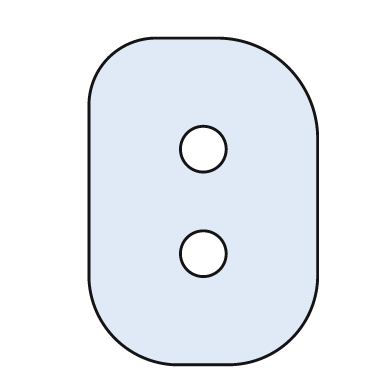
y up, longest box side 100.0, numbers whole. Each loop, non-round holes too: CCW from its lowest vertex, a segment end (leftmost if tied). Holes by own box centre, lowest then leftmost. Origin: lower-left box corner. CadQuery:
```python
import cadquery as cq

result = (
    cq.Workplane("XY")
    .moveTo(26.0, 0.0)
    .lineTo(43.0, 0.0)
    .threePointArc((62.0, 8.0), (70.0, 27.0))
    .lineTo(70.0, 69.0)
    .threePointArc((61.0, 91.0), (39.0, 100.0))
    .lineTo(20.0, 100.0)
    .threePointArc((6.0, 94.0), (0.0, 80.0))
    .lineTo(0.0, 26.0)
    .threePointArc((8.0, 8.0), (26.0, 0.0))
    .close()
    .moveTo(35.0, 34.0)
    .circle(7.0)
    .moveTo(35.0, 66.0)
    .circle(7.0)
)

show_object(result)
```